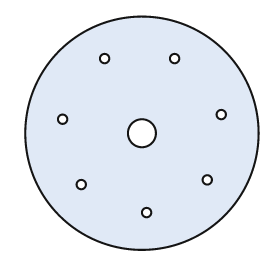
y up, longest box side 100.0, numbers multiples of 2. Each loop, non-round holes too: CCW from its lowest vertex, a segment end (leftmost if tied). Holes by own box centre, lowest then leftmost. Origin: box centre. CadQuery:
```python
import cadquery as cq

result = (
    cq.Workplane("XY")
    .moveTo(0.0, 0.0)
    .circle(50.0)
    .moveTo(2.0, -34.0)
    .circle(2.0)
    .moveTo(-26.0, -22.0)
    .circle(2.0)
    .moveTo(28.0, -20.0)
    .circle(2.0)
    .moveTo(0.0, 0.0)
    .circle(6.0)
    .moveTo(-34.0, 6.0)
    .circle(2.0)
    .moveTo(34.0, 8.0)
    .circle(2.0)
    .moveTo(-16.0, 32.0)
    .circle(2.0)
    .moveTo(14.0, 32.0)
    .circle(2.0)
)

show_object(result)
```